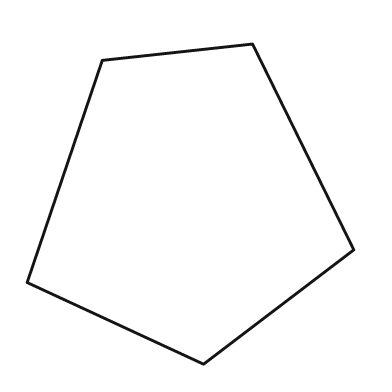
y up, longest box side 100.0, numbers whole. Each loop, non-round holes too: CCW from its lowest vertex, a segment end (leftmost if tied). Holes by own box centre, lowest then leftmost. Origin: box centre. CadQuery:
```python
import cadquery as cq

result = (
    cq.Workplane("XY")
    .moveTo(4.0, -49.0)
    .lineTo(50.0, -14.0)
    .lineTo(19.0, 49.0)
    .lineTo(-27.0, 44.0)
    .lineTo(-50.0, -24.0)
    .close()
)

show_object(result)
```